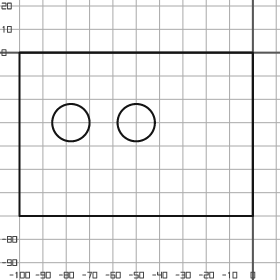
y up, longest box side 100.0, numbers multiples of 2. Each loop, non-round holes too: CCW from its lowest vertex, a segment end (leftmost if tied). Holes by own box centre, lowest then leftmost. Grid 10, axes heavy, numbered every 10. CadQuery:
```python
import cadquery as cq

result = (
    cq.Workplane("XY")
    .moveTo(-100.0, -70.0)
    .lineTo(0.0, -70.0)
    .lineTo(0.0, 0.0)
    .lineTo(-100.0, 0.0)
    .close()
    .moveTo(-78.0, -30.0)
    .circle(8.0)
    .moveTo(-50.0, -30.0)
    .circle(8.0)
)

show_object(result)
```